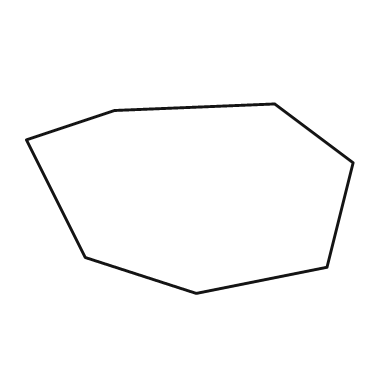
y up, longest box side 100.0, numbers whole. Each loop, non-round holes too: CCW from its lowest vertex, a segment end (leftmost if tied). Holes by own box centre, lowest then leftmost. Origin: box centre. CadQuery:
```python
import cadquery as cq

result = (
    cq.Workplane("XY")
    .moveTo(2.0, -29.0)
    .lineTo(42.0, -21.0)
    .lineTo(50.0, 11.0)
    .lineTo(26.0, 29.0)
    .lineTo(-23.0, 27.0)
    .lineTo(-50.0, 18.0)
    .lineTo(-32.0, -18.0)
    .close()
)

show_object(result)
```